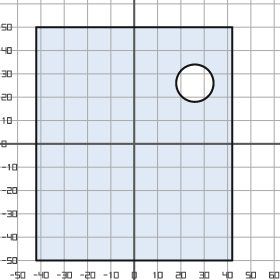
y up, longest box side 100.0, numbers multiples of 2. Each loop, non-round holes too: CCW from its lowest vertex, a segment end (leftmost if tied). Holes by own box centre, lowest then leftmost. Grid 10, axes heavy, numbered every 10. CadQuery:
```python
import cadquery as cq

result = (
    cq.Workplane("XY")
    .moveTo(-42.0, -50.0)
    .lineTo(42.0, -50.0)
    .lineTo(42.0, 50.0)
    .lineTo(-42.0, 50.0)
    .close()
    .moveTo(26.0, 26.0)
    .circle(8.0)
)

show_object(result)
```